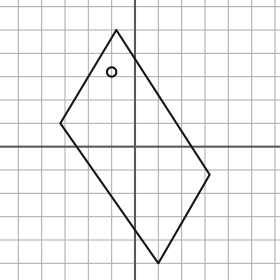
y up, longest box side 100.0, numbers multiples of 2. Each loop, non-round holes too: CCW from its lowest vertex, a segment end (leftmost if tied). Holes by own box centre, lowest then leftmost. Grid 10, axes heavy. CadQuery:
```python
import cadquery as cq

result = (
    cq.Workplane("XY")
    .moveTo(10.0, -50.0)
    .lineTo(32.0, -12.0)
    .lineTo(-8.0, 50.0)
    .lineTo(-32.0, 10.0)
    .close()
    .moveTo(-10.0, 32.0)
    .circle(2.0)
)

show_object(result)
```